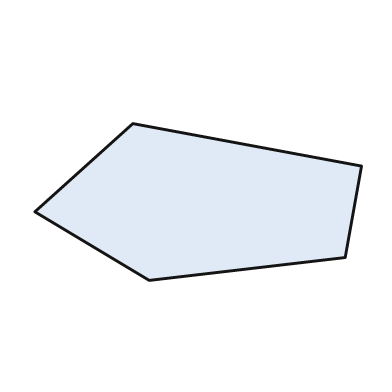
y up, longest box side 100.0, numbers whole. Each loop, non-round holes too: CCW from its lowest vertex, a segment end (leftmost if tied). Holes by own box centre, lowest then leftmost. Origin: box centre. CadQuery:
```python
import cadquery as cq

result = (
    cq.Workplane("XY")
    .moveTo(-15.0, -24.0)
    .lineTo(45.0, -17.0)
    .lineTo(50.0, 11.0)
    .lineTo(-20.0, 24.0)
    .lineTo(-50.0, -3.0)
    .close()
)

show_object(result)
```